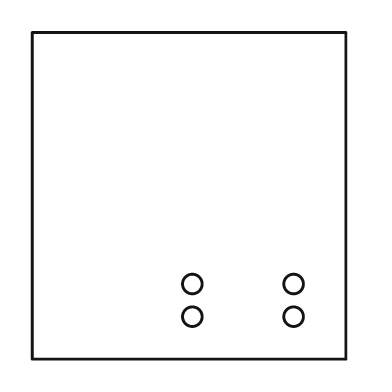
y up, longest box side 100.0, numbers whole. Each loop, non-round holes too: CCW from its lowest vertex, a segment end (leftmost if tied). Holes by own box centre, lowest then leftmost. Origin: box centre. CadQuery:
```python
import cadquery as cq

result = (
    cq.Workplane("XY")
    .moveTo(-48.0, -50.0)
    .lineTo(48.0, -50.0)
    .lineTo(48.0, 50.0)
    .lineTo(-48.0, 50.0)
    .close()
    .moveTo(1.0, -37.0)
    .circle(3.0)
    .moveTo(32.0, -37.0)
    .circle(3.0)
    .moveTo(1.0, -27.0)
    .circle(3.0)
    .moveTo(32.0, -27.0)
    .circle(3.0)
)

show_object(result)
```